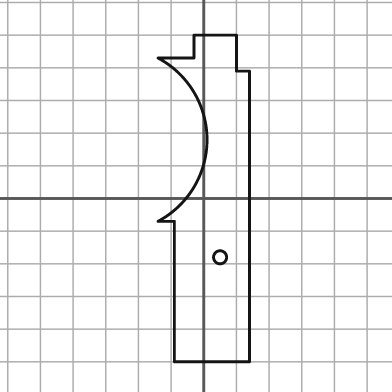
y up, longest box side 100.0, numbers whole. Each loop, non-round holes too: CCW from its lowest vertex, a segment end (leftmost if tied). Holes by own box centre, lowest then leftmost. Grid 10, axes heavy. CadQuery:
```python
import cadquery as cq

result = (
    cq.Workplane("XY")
    .moveTo(-9.0, -50.0)
    .lineTo(14.0, -50.0)
    .lineTo(14.0, 39.0)
    .lineTo(10.0, 39.0)
    .lineTo(10.0, 50.0)
    .lineTo(-3.0, 50.0)
    .lineTo(-3.0, 43.0)
    .lineTo(-14.0, 43.0)
    .threePointArc((1.0, 18.0), (-14.0, -7.0))
    .lineTo(-9.0, -7.0)
    .close()
    .moveTo(5.0, -18.0)
    .circle(2.0)
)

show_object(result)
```